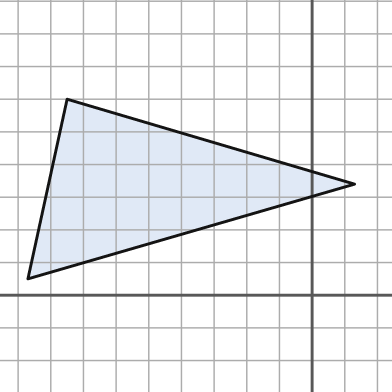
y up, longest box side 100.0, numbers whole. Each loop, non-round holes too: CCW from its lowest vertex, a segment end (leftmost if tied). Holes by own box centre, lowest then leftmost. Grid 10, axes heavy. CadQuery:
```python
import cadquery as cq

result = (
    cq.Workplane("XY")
    .moveTo(-87.0, 5.0)
    .lineTo(13.0, 34.0)
    .lineTo(-75.0, 60.0)
    .close()
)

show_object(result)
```